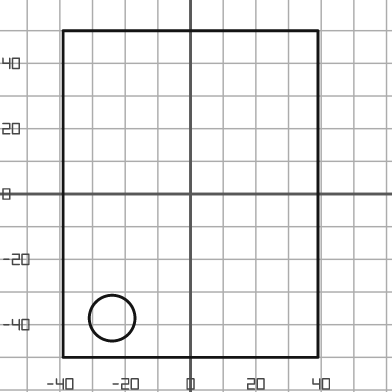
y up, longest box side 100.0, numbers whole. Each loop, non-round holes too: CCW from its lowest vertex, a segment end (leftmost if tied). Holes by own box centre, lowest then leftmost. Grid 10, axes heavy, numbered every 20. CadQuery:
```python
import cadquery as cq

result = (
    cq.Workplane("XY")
    .moveTo(-39.0, -50.0)
    .lineTo(39.0, -50.0)
    .lineTo(39.0, 50.0)
    .lineTo(-39.0, 50.0)
    .close()
    .moveTo(-24.0, -38.0)
    .circle(7.0)
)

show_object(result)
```